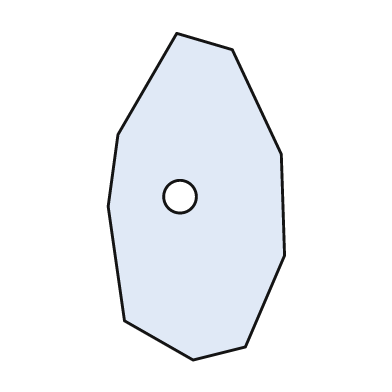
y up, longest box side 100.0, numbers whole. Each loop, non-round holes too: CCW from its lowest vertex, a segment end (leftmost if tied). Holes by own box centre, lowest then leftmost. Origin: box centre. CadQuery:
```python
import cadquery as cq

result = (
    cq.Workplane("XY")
    .moveTo(-1.0, -50.0)
    .lineTo(15.0, -46.0)
    .lineTo(27.0, -18.0)
    .lineTo(26.0, 13.0)
    .lineTo(11.0, 45.0)
    .lineTo(-6.0, 50.0)
    .lineTo(-24.0, 19.0)
    .lineTo(-27.0, -3.0)
    .lineTo(-22.0, -38.0)
    .close()
    .moveTo(-5.0, 0.0)
    .circle(5.0)
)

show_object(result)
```